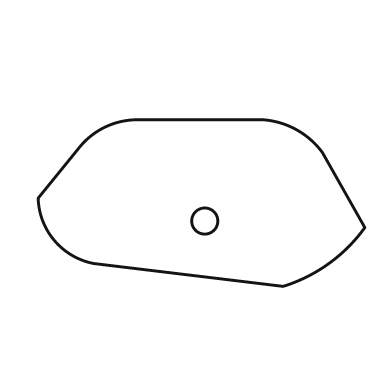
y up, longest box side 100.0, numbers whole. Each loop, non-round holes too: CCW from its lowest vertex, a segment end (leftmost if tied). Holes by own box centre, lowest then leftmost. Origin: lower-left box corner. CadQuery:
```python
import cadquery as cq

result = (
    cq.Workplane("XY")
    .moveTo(75.0, 0.0)
    .threePointArc((89.0, 7.0), (100.0, 18.0))
    .lineTo(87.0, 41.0)
    .threePointArc((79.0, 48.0), (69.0, 51.0))
    .lineTo(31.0, 51.0)
    .threePointArc((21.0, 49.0), (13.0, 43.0))
    .lineTo(0.0, 27.0)
    .threePointArc((5.0, 14.0), (17.0, 7.0))
    .close()
    .moveTo(51.0, 20.0)
    .circle(4.0)
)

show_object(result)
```